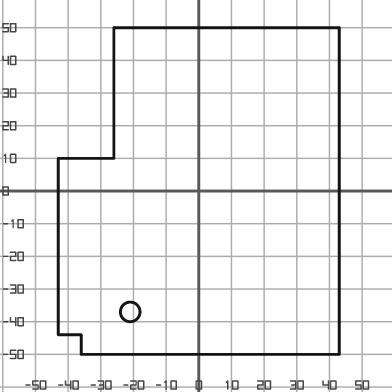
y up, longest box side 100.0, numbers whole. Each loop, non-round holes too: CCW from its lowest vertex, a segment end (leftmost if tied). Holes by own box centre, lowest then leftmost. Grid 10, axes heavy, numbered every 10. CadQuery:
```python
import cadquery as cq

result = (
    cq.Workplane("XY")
    .moveTo(-36.0, -50.0)
    .lineTo(43.0, -50.0)
    .lineTo(43.0, 50.0)
    .lineTo(-26.0, 50.0)
    .lineTo(-26.0, 10.0)
    .lineTo(-43.0, 10.0)
    .lineTo(-43.0, -44.0)
    .lineTo(-36.0, -44.0)
    .close()
    .moveTo(-21.0, -37.0)
    .circle(3.0)
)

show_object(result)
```